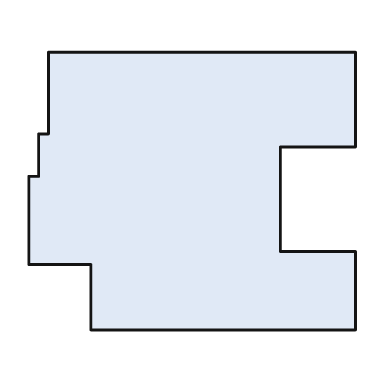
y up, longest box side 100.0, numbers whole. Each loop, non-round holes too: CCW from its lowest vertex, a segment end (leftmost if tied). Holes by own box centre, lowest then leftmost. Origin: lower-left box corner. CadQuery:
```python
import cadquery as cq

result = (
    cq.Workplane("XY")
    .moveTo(19.0, 0.0)
    .lineTo(100.0, 0.0)
    .lineTo(100.0, 24.0)
    .lineTo(77.0, 24.0)
    .lineTo(77.0, 56.0)
    .lineTo(100.0, 56.0)
    .lineTo(100.0, 85.0)
    .lineTo(6.0, 85.0)
    .lineTo(6.0, 60.0)
    .lineTo(3.0, 60.0)
    .lineTo(3.0, 47.0)
    .lineTo(0.0, 47.0)
    .lineTo(0.0, 20.0)
    .lineTo(19.0, 20.0)
    .close()
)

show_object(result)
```